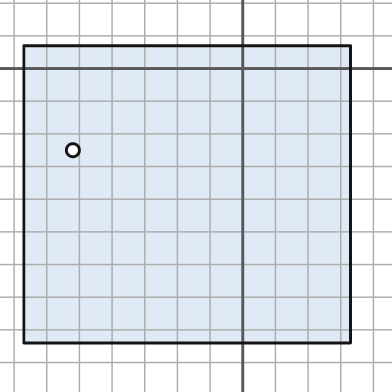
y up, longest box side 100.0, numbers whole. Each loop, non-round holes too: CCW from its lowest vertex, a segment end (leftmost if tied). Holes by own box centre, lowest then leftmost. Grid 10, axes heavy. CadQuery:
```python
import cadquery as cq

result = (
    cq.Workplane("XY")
    .moveTo(-67.0, -84.0)
    .lineTo(33.0, -84.0)
    .lineTo(33.0, 7.0)
    .lineTo(-67.0, 7.0)
    .close()
    .moveTo(-52.0, -25.0)
    .circle(2.0)
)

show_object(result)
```